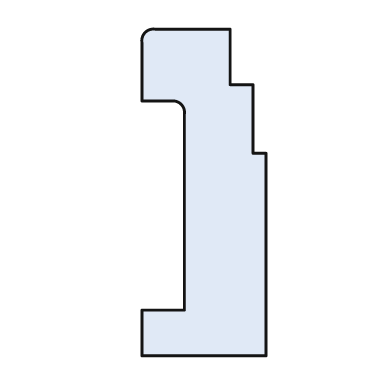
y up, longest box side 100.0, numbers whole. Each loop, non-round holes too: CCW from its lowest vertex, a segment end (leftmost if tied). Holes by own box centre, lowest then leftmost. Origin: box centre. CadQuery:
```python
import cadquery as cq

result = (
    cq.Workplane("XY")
    .moveTo(-19.0, -50.0)
    .lineTo(19.0, -50.0)
    .lineTo(19.0, 12.0)
    .lineTo(15.0, 12.0)
    .lineTo(15.0, 33.0)
    .lineTo(8.0, 33.0)
    .lineTo(8.0, 50.0)
    .lineTo(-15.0, 50.0)
    .threePointArc((-18.0, 49.0), (-19.0, 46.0))
    .lineTo(-19.0, 28.0)
    .lineTo(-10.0, 28.0)
    .threePointArc((-7.0, 27.0), (-6.0, 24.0))
    .lineTo(-6.0, -36.0)
    .lineTo(-19.0, -36.0)
    .close()
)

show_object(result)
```